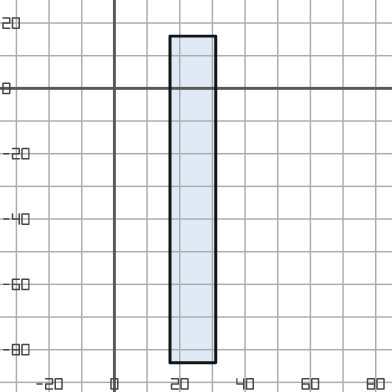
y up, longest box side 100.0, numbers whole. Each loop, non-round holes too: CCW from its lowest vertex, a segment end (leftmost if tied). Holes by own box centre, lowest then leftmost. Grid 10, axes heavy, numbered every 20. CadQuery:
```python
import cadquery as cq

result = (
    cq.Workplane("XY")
    .moveTo(17.0, -84.0)
    .lineTo(31.0, -84.0)
    .lineTo(31.0, 16.0)
    .lineTo(17.0, 16.0)
    .close()
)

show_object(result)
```